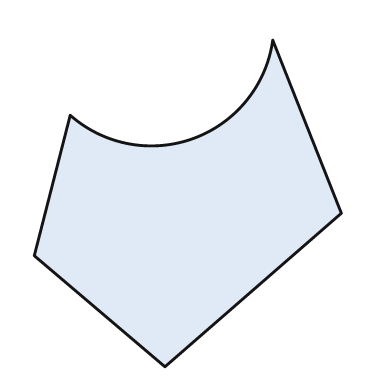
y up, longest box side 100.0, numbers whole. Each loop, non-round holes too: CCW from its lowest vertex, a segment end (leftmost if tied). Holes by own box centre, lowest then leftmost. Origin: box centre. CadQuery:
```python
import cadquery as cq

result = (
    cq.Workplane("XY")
    .moveTo(-7.0, -50.0)
    .lineTo(47.0, -3.0)
    .lineTo(26.0, 50.0)
    .threePointArc((2.0, 20.0), (-36.0, 27.0))
    .lineTo(-47.0, -16.0)
    .close()
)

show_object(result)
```